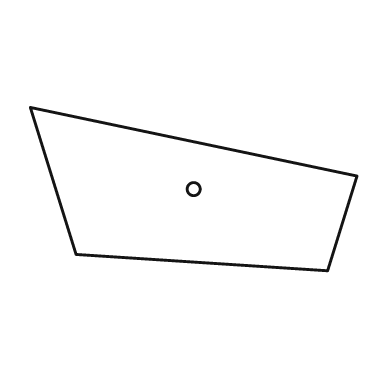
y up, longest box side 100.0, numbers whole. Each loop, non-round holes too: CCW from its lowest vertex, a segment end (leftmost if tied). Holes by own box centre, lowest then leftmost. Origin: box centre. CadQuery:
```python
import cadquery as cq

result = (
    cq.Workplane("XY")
    .moveTo(41.0, -25.0)
    .lineTo(50.0, 4.0)
    .lineTo(-50.0, 25.0)
    .lineTo(-36.0, -20.0)
    .close()
    .moveTo(0.0, 0.0)
    .circle(2.0)
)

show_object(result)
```